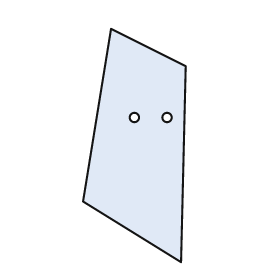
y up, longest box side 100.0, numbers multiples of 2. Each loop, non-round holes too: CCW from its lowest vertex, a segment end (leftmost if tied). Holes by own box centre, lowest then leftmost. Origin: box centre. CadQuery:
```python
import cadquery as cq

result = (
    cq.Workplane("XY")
    .moveTo(20.0, -50.0)
    .lineTo(22.0, 34.0)
    .lineTo(-10.0, 50.0)
    .lineTo(-22.0, -24.0)
    .close()
    .moveTo(0.0, 12.0)
    .circle(2.0)
    .moveTo(14.0, 12.0)
    .circle(2.0)
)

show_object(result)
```